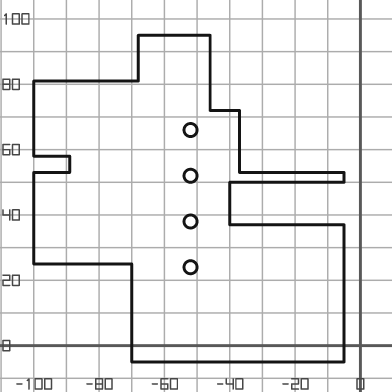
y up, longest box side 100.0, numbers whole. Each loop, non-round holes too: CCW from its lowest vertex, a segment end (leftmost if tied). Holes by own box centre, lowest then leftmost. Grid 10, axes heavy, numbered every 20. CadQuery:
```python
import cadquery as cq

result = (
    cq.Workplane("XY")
    .moveTo(-70.0, -5.0)
    .lineTo(-5.0, -5.0)
    .lineTo(-5.0, 37.0)
    .lineTo(-40.0, 37.0)
    .lineTo(-40.0, 50.0)
    .lineTo(-5.0, 50.0)
    .lineTo(-5.0, 53.0)
    .lineTo(-37.0, 53.0)
    .lineTo(-37.0, 72.0)
    .lineTo(-46.0, 72.0)
    .lineTo(-46.0, 95.0)
    .lineTo(-68.0, 95.0)
    .lineTo(-68.0, 81.0)
    .lineTo(-100.0, 81.0)
    .lineTo(-100.0, 58.0)
    .lineTo(-89.0, 58.0)
    .lineTo(-89.0, 53.0)
    .lineTo(-100.0, 53.0)
    .lineTo(-100.0, 25.0)
    .lineTo(-70.0, 25.0)
    .close()
    .moveTo(-52.0, 24.0)
    .circle(2.0)
    .moveTo(-52.0, 38.0)
    .circle(2.0)
    .moveTo(-52.0, 52.0)
    .circle(2.0)
    .moveTo(-52.0, 66.0)
    .circle(2.0)
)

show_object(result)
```